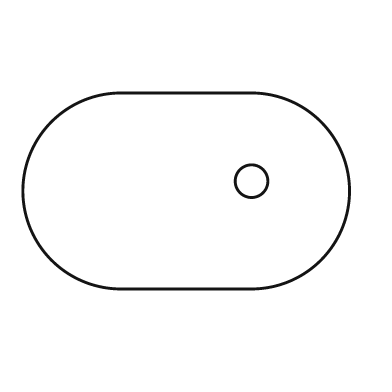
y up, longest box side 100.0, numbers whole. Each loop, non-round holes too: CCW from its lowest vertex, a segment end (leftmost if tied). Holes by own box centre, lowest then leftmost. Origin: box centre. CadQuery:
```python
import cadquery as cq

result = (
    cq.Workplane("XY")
    .moveTo(-20.0, -30.0)
    .lineTo(20.0, -30.0)
    .threePointArc((50.0, 0.0), (20.0, 30.0))
    .lineTo(-20.0, 30.0)
    .threePointArc((-50.0, 0.0), (-20.0, -30.0))
    .close()
    .moveTo(20.0, 3.0)
    .circle(5.0)
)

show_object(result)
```